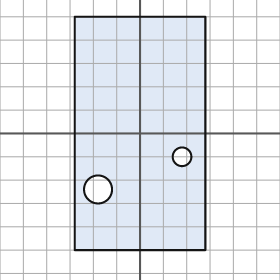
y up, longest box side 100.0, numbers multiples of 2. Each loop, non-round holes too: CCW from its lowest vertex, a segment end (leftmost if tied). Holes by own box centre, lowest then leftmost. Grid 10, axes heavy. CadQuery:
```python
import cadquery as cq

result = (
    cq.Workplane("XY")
    .moveTo(-28.0, -50.0)
    .lineTo(28.0, -50.0)
    .lineTo(28.0, 50.0)
    .lineTo(-28.0, 50.0)
    .close()
    .moveTo(-18.0, -24.0)
    .circle(6.0)
    .moveTo(18.0, -10.0)
    .circle(4.0)
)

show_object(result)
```